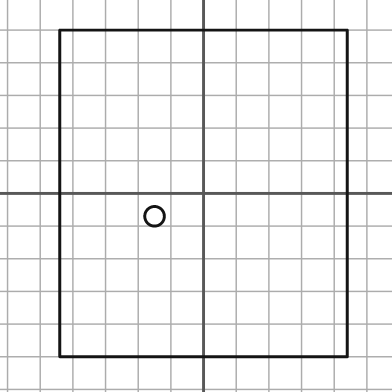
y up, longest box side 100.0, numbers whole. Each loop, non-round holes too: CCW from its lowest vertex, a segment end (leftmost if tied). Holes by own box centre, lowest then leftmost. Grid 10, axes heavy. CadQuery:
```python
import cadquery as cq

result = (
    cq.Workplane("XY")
    .moveTo(-44.0, -50.0)
    .lineTo(44.0, -50.0)
    .lineTo(44.0, 50.0)
    .lineTo(-44.0, 50.0)
    .close()
    .moveTo(-15.0, -7.0)
    .circle(3.0)
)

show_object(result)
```